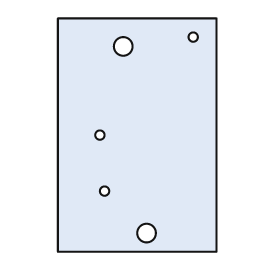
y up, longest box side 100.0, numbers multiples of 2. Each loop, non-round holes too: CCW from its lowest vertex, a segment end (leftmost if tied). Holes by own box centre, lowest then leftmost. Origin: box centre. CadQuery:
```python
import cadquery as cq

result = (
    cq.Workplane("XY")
    .moveTo(-34.0, -50.0)
    .lineTo(34.0, -50.0)
    .lineTo(34.0, 50.0)
    .lineTo(-34.0, 50.0)
    .close()
    .moveTo(4.0, -42.0)
    .circle(4.0)
    .moveTo(-14.0, -24.0)
    .circle(2.0)
    .moveTo(-16.0, 0.0)
    .circle(2.0)
    .moveTo(-6.0, 38.0)
    .circle(4.0)
    .moveTo(24.0, 42.0)
    .circle(2.0)
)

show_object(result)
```